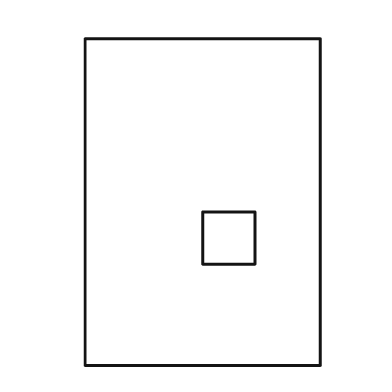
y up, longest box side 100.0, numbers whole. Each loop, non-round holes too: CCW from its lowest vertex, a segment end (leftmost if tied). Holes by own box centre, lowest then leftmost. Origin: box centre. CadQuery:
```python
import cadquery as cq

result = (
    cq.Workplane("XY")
    .moveTo(-36.0, -50.0)
    .lineTo(36.0, -50.0)
    .lineTo(36.0, 50.0)
    .lineTo(-36.0, 50.0)
    .close()
    .moveTo(0.0, -19.0)
    .lineTo(16.0, -19.0)
    .lineTo(16.0, -3.0)
    .lineTo(0.0, -3.0)
    .close()
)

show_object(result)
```